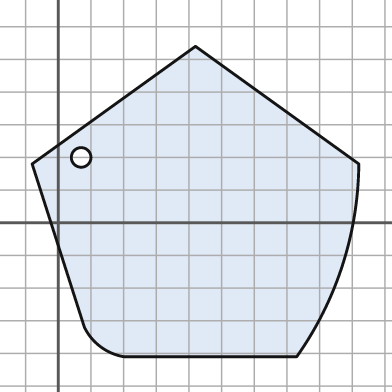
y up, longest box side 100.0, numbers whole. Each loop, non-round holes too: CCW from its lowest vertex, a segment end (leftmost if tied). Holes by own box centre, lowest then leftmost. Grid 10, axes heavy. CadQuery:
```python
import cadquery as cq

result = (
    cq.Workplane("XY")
    .moveTo(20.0, -41.0)
    .lineTo(73.0, -41.0)
    .threePointArc((87.0, -13.0), (92.0, 18.0))
    .lineTo(42.0, 54.0)
    .lineTo(-8.0, 18.0)
    .lineTo(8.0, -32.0)
    .threePointArc((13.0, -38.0), (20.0, -41.0))
    .close()
    .moveTo(7.0, 20.0)
    .circle(3.0)
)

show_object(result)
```